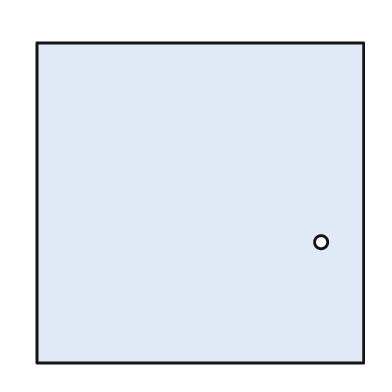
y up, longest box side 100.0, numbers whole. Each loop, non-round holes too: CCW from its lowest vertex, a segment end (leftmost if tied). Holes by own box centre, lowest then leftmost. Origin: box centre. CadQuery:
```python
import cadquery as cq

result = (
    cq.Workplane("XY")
    .moveTo(-50.0, -49.0)
    .lineTo(50.0, -49.0)
    .lineTo(50.0, 49.0)
    .lineTo(-50.0, 49.0)
    .close()
    .moveTo(37.0, -12.0)
    .circle(2.0)
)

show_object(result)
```